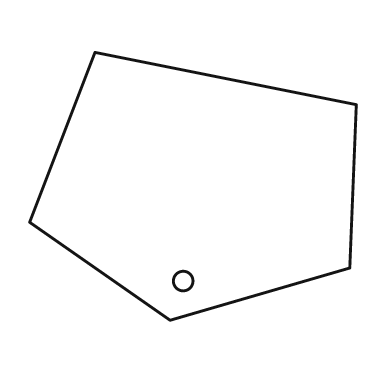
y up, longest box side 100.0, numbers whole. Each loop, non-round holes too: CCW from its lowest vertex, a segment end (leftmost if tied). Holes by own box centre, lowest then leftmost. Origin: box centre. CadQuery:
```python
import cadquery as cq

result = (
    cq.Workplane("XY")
    .moveTo(-7.0, -41.0)
    .lineTo(48.0, -25.0)
    .lineTo(50.0, 25.0)
    .lineTo(-30.0, 41.0)
    .lineTo(-50.0, -11.0)
    .close()
    .moveTo(-3.0, -29.0)
    .circle(3.0)
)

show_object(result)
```